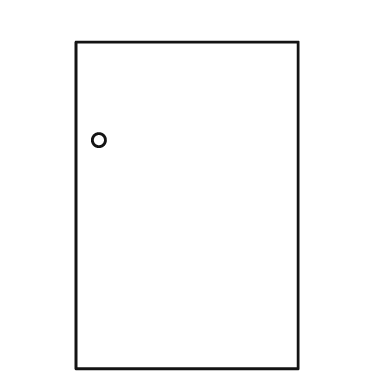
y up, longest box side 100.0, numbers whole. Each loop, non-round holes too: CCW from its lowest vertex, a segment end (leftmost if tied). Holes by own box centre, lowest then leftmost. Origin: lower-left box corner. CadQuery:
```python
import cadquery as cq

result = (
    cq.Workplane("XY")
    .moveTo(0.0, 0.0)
    .lineTo(68.0, 0.0)
    .lineTo(68.0, 100.0)
    .lineTo(0.0, 100.0)
    .close()
    .moveTo(7.0, 70.0)
    .circle(2.0)
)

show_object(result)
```